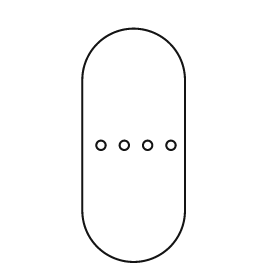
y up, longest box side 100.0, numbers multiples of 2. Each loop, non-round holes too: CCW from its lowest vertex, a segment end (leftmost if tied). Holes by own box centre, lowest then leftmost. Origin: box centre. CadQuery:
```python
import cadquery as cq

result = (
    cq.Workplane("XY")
    .moveTo(-22.0, -28.0)
    .threePointArc((0.0, -50.0), (22.0, -28.0))
    .lineTo(22.0, 28.0)
    .threePointArc((0.0, 50.0), (-22.0, 28.0))
    .close()
    .moveTo(-14.0, 0.0)
    .circle(2.0)
    .moveTo(-4.0, 0.0)
    .circle(2.0)
    .moveTo(6.0, 0.0)
    .circle(2.0)
    .moveTo(16.0, 0.0)
    .circle(2.0)
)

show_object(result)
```